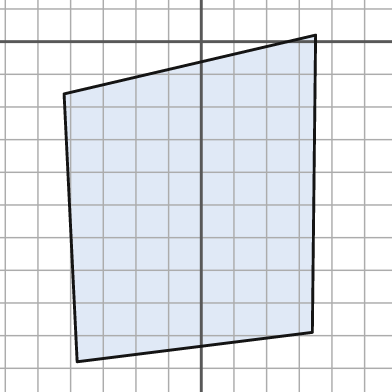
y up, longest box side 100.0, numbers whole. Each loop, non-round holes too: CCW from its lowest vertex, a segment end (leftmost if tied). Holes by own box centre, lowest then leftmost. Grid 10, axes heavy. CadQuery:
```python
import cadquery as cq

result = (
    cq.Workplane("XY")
    .moveTo(-38.0, -98.0)
    .lineTo(34.0, -89.0)
    .lineTo(35.0, 2.0)
    .lineTo(-42.0, -16.0)
    .close()
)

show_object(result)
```